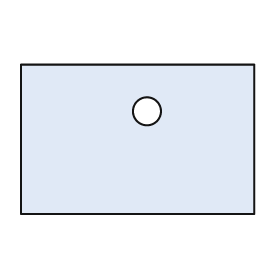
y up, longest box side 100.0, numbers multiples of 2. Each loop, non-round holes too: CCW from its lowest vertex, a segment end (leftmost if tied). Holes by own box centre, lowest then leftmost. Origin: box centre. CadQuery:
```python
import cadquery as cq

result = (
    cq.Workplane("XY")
    .moveTo(-50.0, -32.0)
    .lineTo(50.0, -32.0)
    .lineTo(50.0, 32.0)
    .lineTo(-50.0, 32.0)
    .close()
    .moveTo(4.0, 12.0)
    .circle(6.0)
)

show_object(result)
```